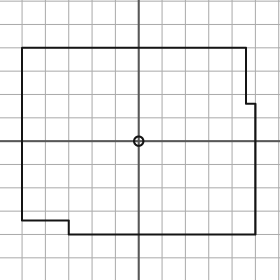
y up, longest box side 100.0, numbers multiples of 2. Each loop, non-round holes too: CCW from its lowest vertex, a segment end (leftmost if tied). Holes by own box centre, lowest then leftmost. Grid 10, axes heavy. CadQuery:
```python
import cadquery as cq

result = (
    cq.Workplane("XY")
    .moveTo(-30.0, -40.0)
    .lineTo(50.0, -40.0)
    .lineTo(50.0, 16.0)
    .lineTo(46.0, 16.0)
    .lineTo(46.0, 40.0)
    .lineTo(-50.0, 40.0)
    .lineTo(-50.0, -34.0)
    .lineTo(-30.0, -34.0)
    .close()
    .moveTo(0.0, 0.0)
    .circle(2.0)
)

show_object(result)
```